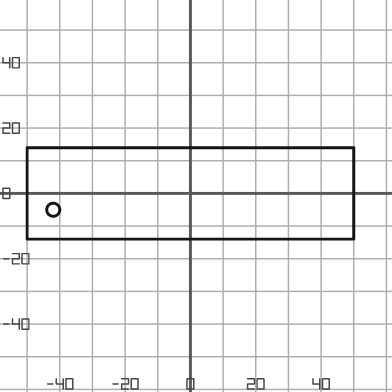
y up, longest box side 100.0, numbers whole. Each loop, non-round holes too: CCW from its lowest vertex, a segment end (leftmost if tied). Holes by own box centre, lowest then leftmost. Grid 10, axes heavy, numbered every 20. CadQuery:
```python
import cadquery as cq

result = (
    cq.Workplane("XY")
    .moveTo(-50.0, -14.0)
    .lineTo(50.0, -14.0)
    .lineTo(50.0, 14.0)
    .lineTo(-50.0, 14.0)
    .close()
    .moveTo(-42.0, -5.0)
    .circle(2.0)
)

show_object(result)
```